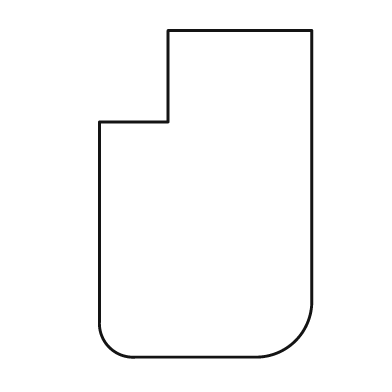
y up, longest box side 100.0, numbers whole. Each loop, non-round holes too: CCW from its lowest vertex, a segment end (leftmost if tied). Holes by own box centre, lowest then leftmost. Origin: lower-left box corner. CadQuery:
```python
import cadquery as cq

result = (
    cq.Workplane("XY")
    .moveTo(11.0, 0.0)
    .lineTo(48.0, 0.0)
    .threePointArc((60.0, 5.0), (65.0, 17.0))
    .lineTo(65.0, 100.0)
    .lineTo(21.0, 100.0)
    .lineTo(21.0, 72.0)
    .lineTo(0.0, 72.0)
    .lineTo(0.0, 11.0)
    .threePointArc((3.0, 3.0), (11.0, 0.0))
    .close()
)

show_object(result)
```